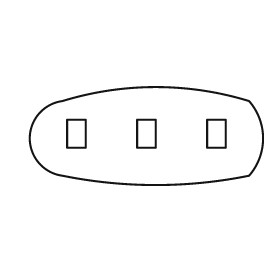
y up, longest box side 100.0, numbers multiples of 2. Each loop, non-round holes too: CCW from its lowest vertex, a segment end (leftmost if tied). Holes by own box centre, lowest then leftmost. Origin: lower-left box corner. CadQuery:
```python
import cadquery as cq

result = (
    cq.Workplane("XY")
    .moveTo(14.0, 4.0)
    .threePointArc((54.0, 0.0), (94.0, 4.0))
    .threePointArc((100.0, 20.0), (94.0, 36.0))
    .threePointArc((54.0, 42.0), (14.0, 36.0))
    .threePointArc((0.0, 20.0), (14.0, 4.0))
    .close()
    .moveTo(16.0, 16.0)
    .lineTo(24.0, 16.0)
    .lineTo(24.0, 28.0)
    .lineTo(16.0, 28.0)
    .close()
    .moveTo(46.0, 16.0)
    .lineTo(54.0, 16.0)
    .lineTo(54.0, 28.0)
    .lineTo(46.0, 28.0)
    .close()
    .moveTo(76.0, 16.0)
    .lineTo(84.0, 16.0)
    .lineTo(84.0, 28.0)
    .lineTo(76.0, 28.0)
    .close()
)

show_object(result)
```